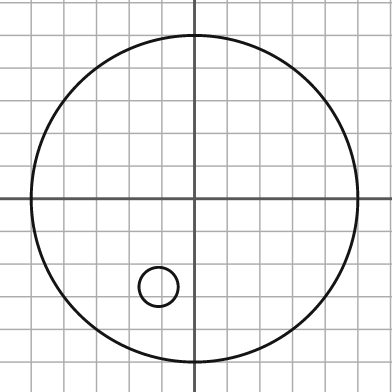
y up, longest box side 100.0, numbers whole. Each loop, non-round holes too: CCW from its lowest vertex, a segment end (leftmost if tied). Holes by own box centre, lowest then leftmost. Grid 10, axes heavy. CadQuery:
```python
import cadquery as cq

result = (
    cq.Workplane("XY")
    .moveTo(0.0, 0.0)
    .circle(50.0)
    .moveTo(-11.0, -27.0)
    .circle(6.0)
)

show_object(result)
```